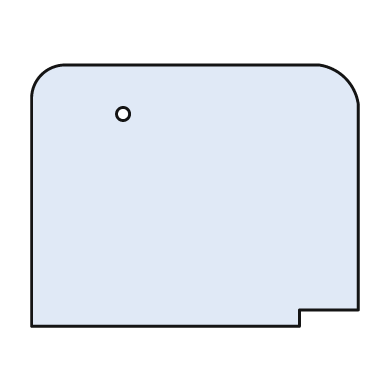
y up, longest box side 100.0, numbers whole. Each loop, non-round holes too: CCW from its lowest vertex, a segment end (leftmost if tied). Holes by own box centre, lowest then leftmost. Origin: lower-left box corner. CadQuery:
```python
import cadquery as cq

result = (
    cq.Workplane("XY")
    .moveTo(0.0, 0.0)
    .lineTo(82.0, 0.0)
    .lineTo(82.0, 5.0)
    .lineTo(100.0, 5.0)
    .lineTo(100.0, 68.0)
    .threePointArc((96.0, 76.0), (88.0, 80.0))
    .lineTo(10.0, 80.0)
    .threePointArc((3.0, 77.0), (0.0, 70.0))
    .close()
    .moveTo(28.0, 65.0)
    .circle(2.0)
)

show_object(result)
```